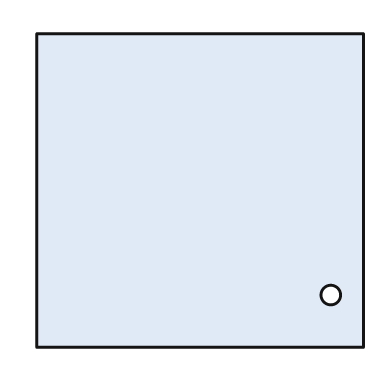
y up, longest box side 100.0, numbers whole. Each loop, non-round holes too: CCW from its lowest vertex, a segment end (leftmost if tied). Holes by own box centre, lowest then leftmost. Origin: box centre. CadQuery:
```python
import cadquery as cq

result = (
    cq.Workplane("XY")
    .moveTo(-50.0, -48.0)
    .lineTo(50.0, -48.0)
    .lineTo(50.0, 48.0)
    .lineTo(-50.0, 48.0)
    .close()
    .moveTo(40.0, -32.0)
    .circle(3.0)
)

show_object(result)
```